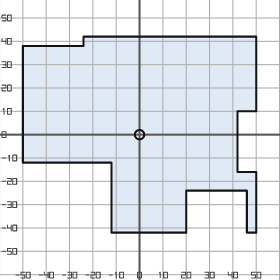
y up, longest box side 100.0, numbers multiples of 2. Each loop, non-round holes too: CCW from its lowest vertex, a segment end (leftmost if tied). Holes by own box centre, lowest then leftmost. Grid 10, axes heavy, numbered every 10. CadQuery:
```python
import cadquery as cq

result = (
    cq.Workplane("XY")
    .moveTo(-12.0, -42.0)
    .lineTo(20.0, -42.0)
    .lineTo(20.0, -24.0)
    .lineTo(46.0, -24.0)
    .lineTo(46.0, -42.0)
    .lineTo(50.0, -42.0)
    .lineTo(50.0, -16.0)
    .lineTo(42.0, -16.0)
    .lineTo(42.0, 10.0)
    .lineTo(50.0, 10.0)
    .lineTo(50.0, 42.0)
    .lineTo(-24.0, 42.0)
    .lineTo(-24.0, 38.0)
    .lineTo(-50.0, 38.0)
    .lineTo(-50.0, -12.0)
    .lineTo(-12.0, -12.0)
    .close()
    .moveTo(0.0, 0.0)
    .circle(2.0)
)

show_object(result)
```